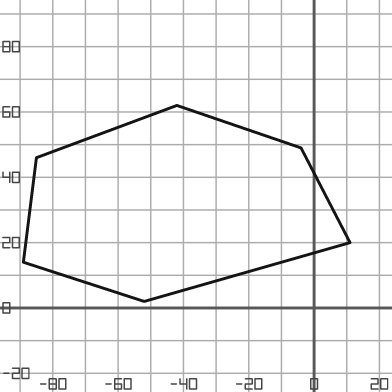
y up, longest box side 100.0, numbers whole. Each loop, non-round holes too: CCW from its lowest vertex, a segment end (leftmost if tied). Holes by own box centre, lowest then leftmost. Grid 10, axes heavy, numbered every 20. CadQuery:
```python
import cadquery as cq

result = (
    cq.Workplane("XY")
    .moveTo(-52.0, 2.0)
    .lineTo(11.0, 20.0)
    .lineTo(-4.0, 49.0)
    .lineTo(-42.0, 62.0)
    .lineTo(-85.0, 46.0)
    .lineTo(-89.0, 14.0)
    .close()
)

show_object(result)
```